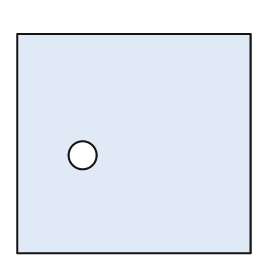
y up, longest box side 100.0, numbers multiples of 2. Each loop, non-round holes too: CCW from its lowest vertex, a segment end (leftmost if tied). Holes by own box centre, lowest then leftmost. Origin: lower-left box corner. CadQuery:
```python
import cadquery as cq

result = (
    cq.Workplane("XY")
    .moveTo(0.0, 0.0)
    .lineTo(100.0, 0.0)
    .lineTo(100.0, 94.0)
    .lineTo(0.0, 94.0)
    .close()
    .moveTo(28.0, 42.0)
    .circle(6.0)
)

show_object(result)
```